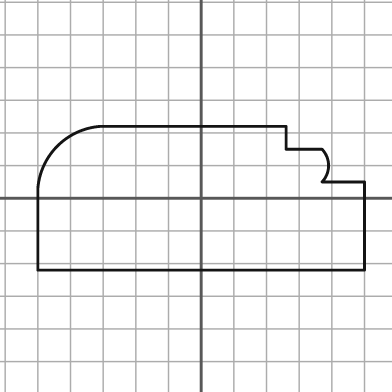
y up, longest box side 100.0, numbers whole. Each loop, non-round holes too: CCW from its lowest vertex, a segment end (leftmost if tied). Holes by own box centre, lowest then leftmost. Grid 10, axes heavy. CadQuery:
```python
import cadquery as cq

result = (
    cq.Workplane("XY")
    .moveTo(-50.0, -22.0)
    .lineTo(50.0, -22.0)
    .lineTo(50.0, 5.0)
    .lineTo(37.0, 5.0)
    .threePointArc((39.0, 10.0), (37.0, 15.0))
    .lineTo(26.0, 15.0)
    .lineTo(26.0, 22.0)
    .lineTo(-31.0, 22.0)
    .threePointArc((-44.0, 16.0), (-50.0, 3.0))
    .close()
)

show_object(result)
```